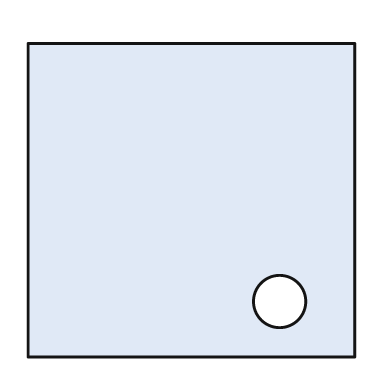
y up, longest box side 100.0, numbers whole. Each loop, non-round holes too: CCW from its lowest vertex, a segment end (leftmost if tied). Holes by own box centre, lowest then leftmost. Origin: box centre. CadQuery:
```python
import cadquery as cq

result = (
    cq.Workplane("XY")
    .moveTo(-50.0, -48.0)
    .lineTo(50.0, -48.0)
    .lineTo(50.0, 48.0)
    .lineTo(-50.0, 48.0)
    .close()
    .moveTo(27.0, -31.0)
    .circle(8.0)
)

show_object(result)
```